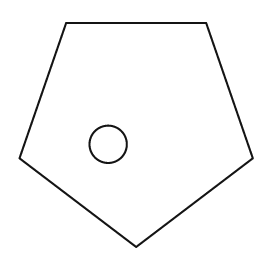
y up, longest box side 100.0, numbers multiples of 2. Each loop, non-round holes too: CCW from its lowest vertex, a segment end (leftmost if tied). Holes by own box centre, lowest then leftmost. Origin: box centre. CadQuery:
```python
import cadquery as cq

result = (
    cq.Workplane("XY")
    .moveTo(0.0, -48.0)
    .lineTo(50.0, -10.0)
    .lineTo(30.0, 48.0)
    .lineTo(-30.0, 48.0)
    .lineTo(-50.0, -10.0)
    .close()
    .moveTo(-12.0, -4.0)
    .circle(8.0)
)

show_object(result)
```